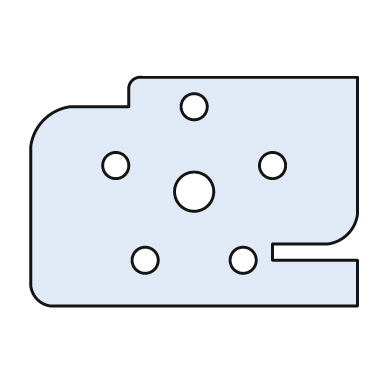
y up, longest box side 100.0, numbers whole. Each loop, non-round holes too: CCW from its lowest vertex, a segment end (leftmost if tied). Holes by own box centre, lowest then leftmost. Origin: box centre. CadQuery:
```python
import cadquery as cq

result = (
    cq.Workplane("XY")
    .moveTo(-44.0, -35.0)
    .lineTo(50.0, -35.0)
    .lineTo(50.0, -21.0)
    .lineTo(24.0, -21.0)
    .lineTo(24.0, -16.0)
    .lineTo(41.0, -16.0)
    .threePointArc((47.0, -13.0), (50.0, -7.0))
    .lineTo(50.0, 35.0)
    .lineTo(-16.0, 35.0)
    .threePointArc((-19.0, 34.0), (-20.0, 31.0))
    .lineTo(-20.0, 26.0)
    .lineTo(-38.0, 26.0)
    .threePointArc((-46.0, 22.0), (-50.0, 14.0))
    .lineTo(-50.0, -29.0)
    .threePointArc((-48.0, -33.0), (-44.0, -35.0))
    .close()
    .moveTo(-15.0, -21.0)
    .circle(4.0)
    .moveTo(15.0, -21.0)
    .circle(4.0)
    .moveTo(0.0, 0.0)
    .circle(6.0)
    .moveTo(-24.0, 8.0)
    .circle(4.0)
    .moveTo(24.0, 8.0)
    .circle(4.0)
    .moveTo(0.0, 26.0)
    .circle(4.0)
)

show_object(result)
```